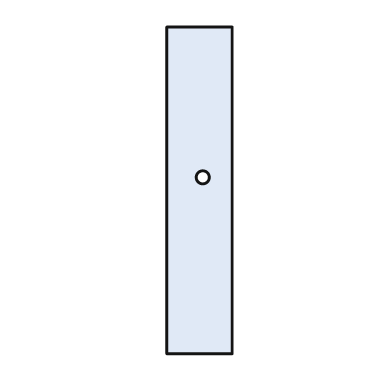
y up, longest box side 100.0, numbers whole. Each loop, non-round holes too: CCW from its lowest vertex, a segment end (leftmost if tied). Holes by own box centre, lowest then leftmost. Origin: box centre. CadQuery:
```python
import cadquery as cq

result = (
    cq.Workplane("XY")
    .moveTo(-10.0, -50.0)
    .lineTo(10.0, -50.0)
    .lineTo(10.0, 50.0)
    .lineTo(-10.0, 50.0)
    .close()
    .moveTo(1.0, 4.0)
    .circle(2.0)
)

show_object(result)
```